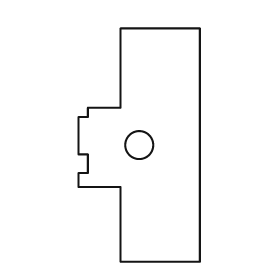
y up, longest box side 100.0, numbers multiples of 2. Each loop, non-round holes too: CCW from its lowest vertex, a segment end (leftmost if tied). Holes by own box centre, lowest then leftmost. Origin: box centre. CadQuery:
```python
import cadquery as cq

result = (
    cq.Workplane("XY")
    .moveTo(-8.0, -50.0)
    .lineTo(26.0, -50.0)
    .lineTo(26.0, 50.0)
    .lineTo(-8.0, 50.0)
    .lineTo(-8.0, 16.0)
    .lineTo(-22.0, 16.0)
    .lineTo(-22.0, 12.0)
    .lineTo(-26.0, 12.0)
    .lineTo(-26.0, -4.0)
    .lineTo(-22.0, -4.0)
    .lineTo(-22.0, -12.0)
    .lineTo(-26.0, -12.0)
    .lineTo(-26.0, -18.0)
    .lineTo(-8.0, -18.0)
    .close()
    .moveTo(0.0, 0.0)
    .circle(6.0)
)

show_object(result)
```